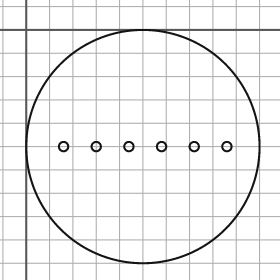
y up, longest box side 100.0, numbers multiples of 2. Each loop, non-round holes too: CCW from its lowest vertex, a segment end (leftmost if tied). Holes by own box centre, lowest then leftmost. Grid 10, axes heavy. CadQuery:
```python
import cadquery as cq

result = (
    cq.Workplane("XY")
    .moveTo(50.0, -50.0)
    .circle(50.0)
    .moveTo(16.0, -50.0)
    .circle(2.0)
    .moveTo(30.0, -50.0)
    .circle(2.0)
    .moveTo(44.0, -50.0)
    .circle(2.0)
    .moveTo(58.0, -50.0)
    .circle(2.0)
    .moveTo(72.0, -50.0)
    .circle(2.0)
    .moveTo(86.0, -50.0)
    .circle(2.0)
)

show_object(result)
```